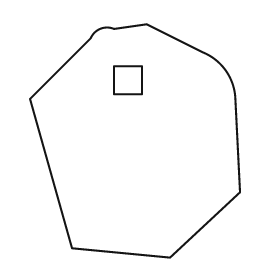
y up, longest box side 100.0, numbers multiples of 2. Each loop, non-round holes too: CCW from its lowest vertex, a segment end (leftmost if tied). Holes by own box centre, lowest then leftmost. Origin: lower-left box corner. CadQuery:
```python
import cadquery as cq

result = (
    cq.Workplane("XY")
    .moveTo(60.0, 0.0)
    .lineTo(90.0, 28.0)
    .lineTo(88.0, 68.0)
    .threePointArc((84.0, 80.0), (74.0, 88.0))
    .lineTo(50.0, 100.0)
    .lineTo(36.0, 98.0)
    .threePointArc((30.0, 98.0), (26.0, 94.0))
    .lineTo(0.0, 68.0)
    .lineTo(18.0, 4.0)
    .close()
    .moveTo(36.0, 70.0)
    .lineTo(48.0, 70.0)
    .lineTo(48.0, 82.0)
    .lineTo(36.0, 82.0)
    .close()
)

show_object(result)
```